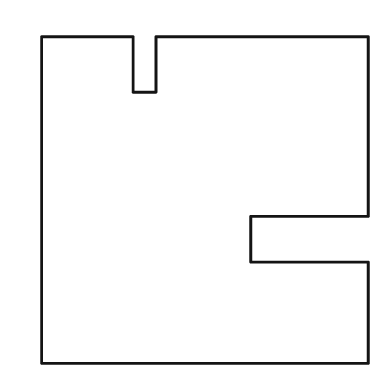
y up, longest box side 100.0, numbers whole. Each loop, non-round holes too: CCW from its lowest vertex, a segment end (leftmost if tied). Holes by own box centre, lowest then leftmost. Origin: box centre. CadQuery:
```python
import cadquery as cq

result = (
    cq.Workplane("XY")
    .moveTo(-50.0, -50.0)
    .lineTo(50.0, -50.0)
    .lineTo(50.0, -19.0)
    .lineTo(14.0, -19.0)
    .lineTo(14.0, -5.0)
    .lineTo(50.0, -5.0)
    .lineTo(50.0, 50.0)
    .lineTo(-15.0, 50.0)
    .lineTo(-15.0, 33.0)
    .lineTo(-22.0, 33.0)
    .lineTo(-22.0, 50.0)
    .lineTo(-50.0, 50.0)
    .close()
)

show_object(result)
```